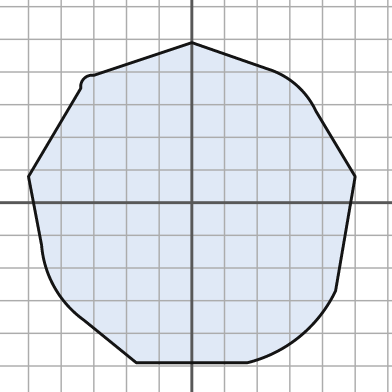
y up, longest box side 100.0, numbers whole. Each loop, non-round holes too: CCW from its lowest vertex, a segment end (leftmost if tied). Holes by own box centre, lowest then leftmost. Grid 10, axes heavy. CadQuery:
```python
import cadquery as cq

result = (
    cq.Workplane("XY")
    .moveTo(-17.0, -49.0)
    .lineTo(17.0, -49.0)
    .threePointArc((33.0, -41.0), (44.0, -27.0))
    .lineTo(50.0, 8.0)
    .lineTo(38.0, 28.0)
    .threePointArc((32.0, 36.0), (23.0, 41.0))
    .lineTo(0.0, 49.0)
    .lineTo(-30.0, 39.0)
    .threePointArc((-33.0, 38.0), (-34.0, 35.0))
    .lineTo(-50.0, 8.0)
    .lineTo(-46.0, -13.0)
    .threePointArc((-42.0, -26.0), (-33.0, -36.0))
    .close()
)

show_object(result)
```